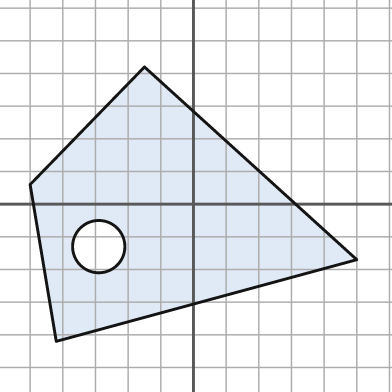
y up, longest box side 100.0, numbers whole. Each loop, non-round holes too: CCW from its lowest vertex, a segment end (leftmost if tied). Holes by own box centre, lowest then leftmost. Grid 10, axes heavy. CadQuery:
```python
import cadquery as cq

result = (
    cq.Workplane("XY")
    .moveTo(-42.0, -42.0)
    .lineTo(50.0, -17.0)
    .lineTo(-15.0, 42.0)
    .lineTo(-50.0, 6.0)
    .close()
    .moveTo(-29.0, -13.0)
    .circle(8.0)
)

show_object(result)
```